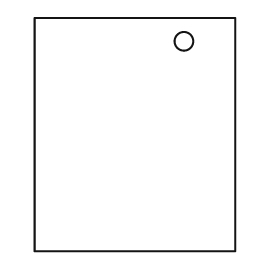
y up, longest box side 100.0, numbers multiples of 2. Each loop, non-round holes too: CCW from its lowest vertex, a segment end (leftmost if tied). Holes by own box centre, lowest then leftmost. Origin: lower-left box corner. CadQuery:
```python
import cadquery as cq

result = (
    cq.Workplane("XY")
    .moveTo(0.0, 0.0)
    .lineTo(86.0, 0.0)
    .lineTo(86.0, 100.0)
    .lineTo(0.0, 100.0)
    .close()
    .moveTo(64.0, 90.0)
    .circle(4.0)
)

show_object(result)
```